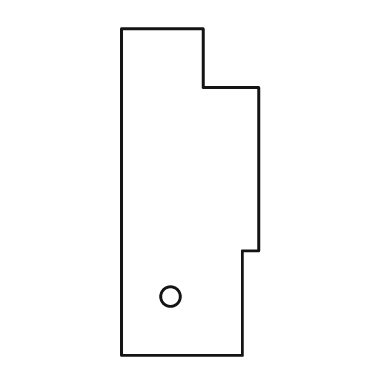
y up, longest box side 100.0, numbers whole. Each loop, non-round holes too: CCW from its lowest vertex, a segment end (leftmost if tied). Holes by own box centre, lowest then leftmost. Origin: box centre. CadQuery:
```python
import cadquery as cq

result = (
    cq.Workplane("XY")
    .moveTo(-21.0, -50.0)
    .lineTo(16.0, -50.0)
    .lineTo(16.0, -18.0)
    .lineTo(21.0, -18.0)
    .lineTo(21.0, 32.0)
    .lineTo(4.0, 32.0)
    .lineTo(4.0, 50.0)
    .lineTo(-21.0, 50.0)
    .close()
    .moveTo(-6.0, -32.0)
    .circle(3.0)
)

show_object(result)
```